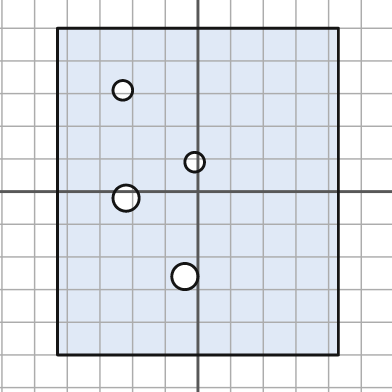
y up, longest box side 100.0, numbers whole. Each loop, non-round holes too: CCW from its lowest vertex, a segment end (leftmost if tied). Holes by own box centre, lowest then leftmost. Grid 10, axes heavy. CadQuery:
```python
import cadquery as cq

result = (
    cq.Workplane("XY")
    .moveTo(-43.0, -50.0)
    .lineTo(43.0, -50.0)
    .lineTo(43.0, 50.0)
    .lineTo(-43.0, 50.0)
    .close()
    .moveTo(-4.0, -26.0)
    .circle(4.0)
    .moveTo(-22.0, -2.0)
    .circle(4.0)
    .moveTo(-1.0, 9.0)
    .circle(3.0)
    .moveTo(-23.0, 31.0)
    .circle(3.0)
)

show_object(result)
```